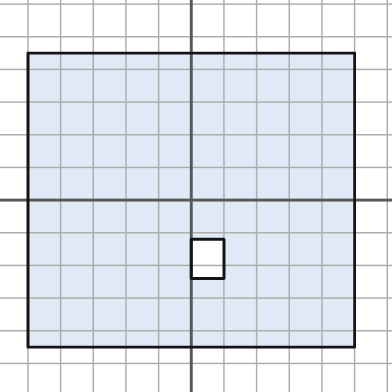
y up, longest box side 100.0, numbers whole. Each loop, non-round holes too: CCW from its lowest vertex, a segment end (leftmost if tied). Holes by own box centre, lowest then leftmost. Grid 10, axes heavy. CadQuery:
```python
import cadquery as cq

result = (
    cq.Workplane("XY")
    .moveTo(-50.0, -45.0)
    .lineTo(50.0, -45.0)
    .lineTo(50.0, 45.0)
    .lineTo(-50.0, 45.0)
    .close()
    .moveTo(0.0, -24.0)
    .lineTo(10.0, -24.0)
    .lineTo(10.0, -12.0)
    .lineTo(0.0, -12.0)
    .close()
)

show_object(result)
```